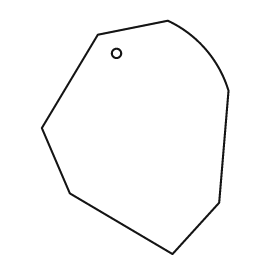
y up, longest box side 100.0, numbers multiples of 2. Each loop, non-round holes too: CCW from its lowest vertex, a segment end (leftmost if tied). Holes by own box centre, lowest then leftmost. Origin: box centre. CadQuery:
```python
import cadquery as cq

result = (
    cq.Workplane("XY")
    .moveTo(16.0, -50.0)
    .lineTo(36.0, -28.0)
    .lineTo(40.0, 20.0)
    .threePointArc((30.0, 38.0), (14.0, 50.0))
    .lineTo(-16.0, 44.0)
    .lineTo(-40.0, 4.0)
    .lineTo(-28.0, -24.0)
    .close()
    .moveTo(-8.0, 36.0)
    .circle(2.0)
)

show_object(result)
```